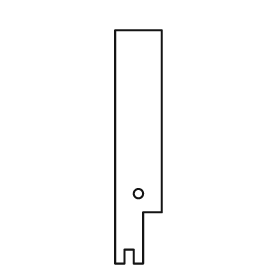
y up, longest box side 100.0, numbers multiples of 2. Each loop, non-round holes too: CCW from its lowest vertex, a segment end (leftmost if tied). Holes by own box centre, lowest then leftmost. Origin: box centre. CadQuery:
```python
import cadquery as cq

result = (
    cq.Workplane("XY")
    .moveTo(-10.0, -50.0)
    .lineTo(-6.0, -50.0)
    .lineTo(-6.0, -44.0)
    .lineTo(-2.0, -44.0)
    .lineTo(-2.0, -50.0)
    .lineTo(2.0, -50.0)
    .lineTo(2.0, -28.0)
    .lineTo(10.0, -28.0)
    .lineTo(10.0, 50.0)
    .lineTo(-10.0, 50.0)
    .close()
    .moveTo(0.0, -20.0)
    .circle(2.0)
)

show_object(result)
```